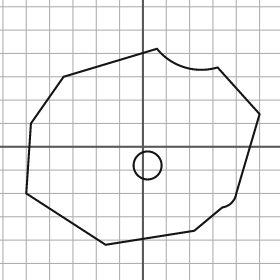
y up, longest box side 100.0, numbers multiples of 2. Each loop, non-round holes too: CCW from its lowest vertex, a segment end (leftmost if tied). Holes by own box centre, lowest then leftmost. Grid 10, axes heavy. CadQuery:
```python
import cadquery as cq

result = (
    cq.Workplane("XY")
    .moveTo(-16.0, -42.0)
    .lineTo(22.0, -36.0)
    .lineTo(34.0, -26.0)
    .threePointArc((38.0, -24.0), (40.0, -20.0))
    .lineTo(50.0, 14.0)
    .lineTo(32.0, 34.0)
    .threePointArc((18.0, 34.0), (6.0, 42.0))
    .lineTo(-34.0, 30.0)
    .lineTo(-48.0, 10.0)
    .lineTo(-50.0, -20.0)
    .close()
    .moveTo(2.0, -8.0)
    .circle(6.0)
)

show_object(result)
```